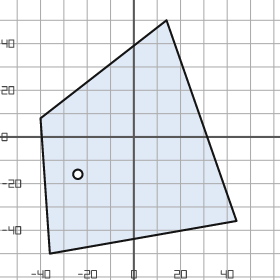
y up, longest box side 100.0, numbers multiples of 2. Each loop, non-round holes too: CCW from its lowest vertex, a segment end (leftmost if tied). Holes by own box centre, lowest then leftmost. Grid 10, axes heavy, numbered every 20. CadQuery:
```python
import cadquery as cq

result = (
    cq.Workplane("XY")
    .moveTo(-36.0, -50.0)
    .lineTo(44.0, -36.0)
    .lineTo(14.0, 50.0)
    .lineTo(-40.0, 8.0)
    .close()
    .moveTo(-24.0, -16.0)
    .circle(2.0)
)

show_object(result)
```